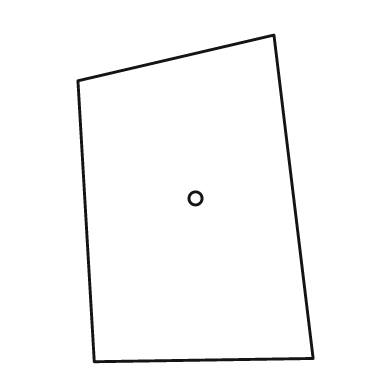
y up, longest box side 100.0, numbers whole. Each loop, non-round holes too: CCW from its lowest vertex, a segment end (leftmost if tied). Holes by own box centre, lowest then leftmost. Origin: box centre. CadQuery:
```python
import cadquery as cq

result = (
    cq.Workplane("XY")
    .moveTo(-31.0, -50.0)
    .lineTo(36.0, -49.0)
    .lineTo(24.0, 50.0)
    .lineTo(-36.0, 36.0)
    .close()
    .moveTo(0.0, 0.0)
    .circle(2.0)
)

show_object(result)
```